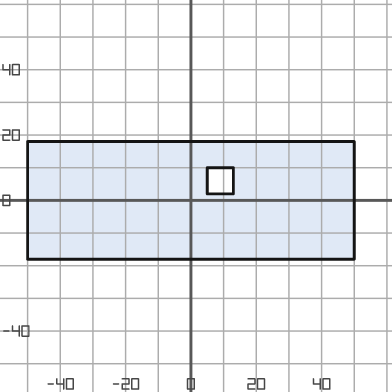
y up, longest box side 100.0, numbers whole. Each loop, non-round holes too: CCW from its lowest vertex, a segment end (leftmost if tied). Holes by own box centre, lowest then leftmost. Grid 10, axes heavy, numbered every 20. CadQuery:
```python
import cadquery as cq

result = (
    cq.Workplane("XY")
    .moveTo(-50.0, -18.0)
    .lineTo(50.0, -18.0)
    .lineTo(50.0, 18.0)
    .lineTo(-50.0, 18.0)
    .close()
    .moveTo(5.0, 2.0)
    .lineTo(13.0, 2.0)
    .lineTo(13.0, 10.0)
    .lineTo(5.0, 10.0)
    .close()
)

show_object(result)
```